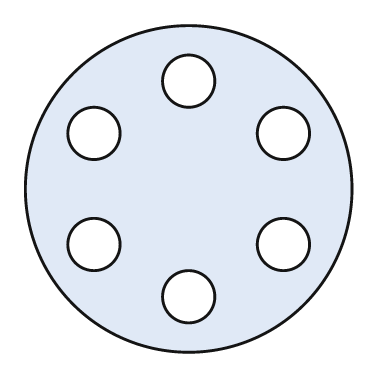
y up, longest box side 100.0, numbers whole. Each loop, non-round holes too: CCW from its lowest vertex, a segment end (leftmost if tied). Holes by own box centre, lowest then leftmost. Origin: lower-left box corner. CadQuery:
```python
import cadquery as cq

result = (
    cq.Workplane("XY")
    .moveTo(50.0, 50.0)
    .circle(50.0)
    .moveTo(50.0, 17.0)
    .circle(8.0)
    .moveTo(21.0, 33.0)
    .circle(8.0)
    .moveTo(79.0, 33.0)
    .circle(8.0)
    .moveTo(21.0, 67.0)
    .circle(8.0)
    .moveTo(79.0, 67.0)
    .circle(8.0)
    .moveTo(50.0, 83.0)
    .circle(8.0)
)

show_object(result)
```